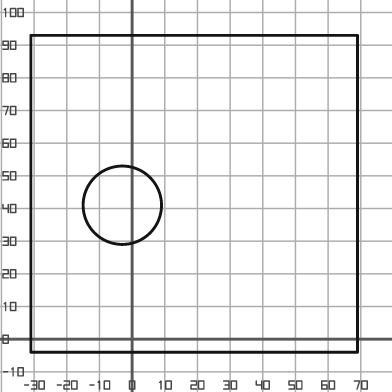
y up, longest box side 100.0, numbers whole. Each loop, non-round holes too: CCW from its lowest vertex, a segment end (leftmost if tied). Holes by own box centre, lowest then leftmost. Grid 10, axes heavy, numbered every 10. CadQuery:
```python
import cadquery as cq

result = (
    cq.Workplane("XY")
    .moveTo(-31.0, -4.0)
    .lineTo(69.0, -4.0)
    .lineTo(69.0, 93.0)
    .lineTo(-31.0, 93.0)
    .close()
    .moveTo(-3.0, 41.0)
    .circle(12.0)
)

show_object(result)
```